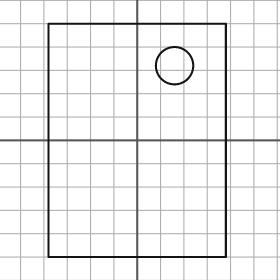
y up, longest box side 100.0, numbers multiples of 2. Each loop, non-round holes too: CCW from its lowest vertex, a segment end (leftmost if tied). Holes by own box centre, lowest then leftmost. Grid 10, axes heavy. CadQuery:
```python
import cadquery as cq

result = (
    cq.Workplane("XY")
    .moveTo(-38.0, -50.0)
    .lineTo(38.0, -50.0)
    .lineTo(38.0, 50.0)
    .lineTo(-38.0, 50.0)
    .close()
    .moveTo(16.0, 32.0)
    .circle(8.0)
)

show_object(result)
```